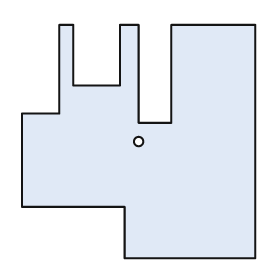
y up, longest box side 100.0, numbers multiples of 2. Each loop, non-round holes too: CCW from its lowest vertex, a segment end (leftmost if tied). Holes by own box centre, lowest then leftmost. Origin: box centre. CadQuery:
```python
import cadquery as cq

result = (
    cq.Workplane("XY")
    .moveTo(-6.0, -50.0)
    .lineTo(50.0, -50.0)
    .lineTo(50.0, 50.0)
    .lineTo(14.0, 50.0)
    .lineTo(14.0, 8.0)
    .lineTo(0.0, 8.0)
    .lineTo(0.0, 50.0)
    .lineTo(-8.0, 50.0)
    .lineTo(-8.0, 24.0)
    .lineTo(-28.0, 24.0)
    .lineTo(-28.0, 50.0)
    .lineTo(-34.0, 50.0)
    .lineTo(-34.0, 12.0)
    .lineTo(-50.0, 12.0)
    .lineTo(-50.0, -28.0)
    .lineTo(-6.0, -28.0)
    .close()
    .moveTo(0.0, 0.0)
    .circle(2.0)
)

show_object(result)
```